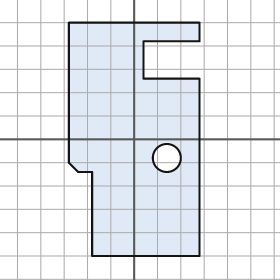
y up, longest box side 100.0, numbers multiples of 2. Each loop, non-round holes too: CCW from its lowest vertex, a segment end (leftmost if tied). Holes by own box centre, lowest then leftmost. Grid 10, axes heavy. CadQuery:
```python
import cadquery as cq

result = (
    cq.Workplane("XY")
    .moveTo(-18.0, -50.0)
    .lineTo(28.0, -50.0)
    .lineTo(28.0, 26.0)
    .lineTo(4.0, 26.0)
    .lineTo(4.0, 42.0)
    .lineTo(28.0, 42.0)
    .lineTo(28.0, 50.0)
    .lineTo(-28.0, 50.0)
    .lineTo(-28.0, -10.0)
    .lineTo(-24.0, -14.0)
    .lineTo(-18.0, -14.0)
    .close()
    .moveTo(14.0, -8.0)
    .circle(6.0)
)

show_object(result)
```